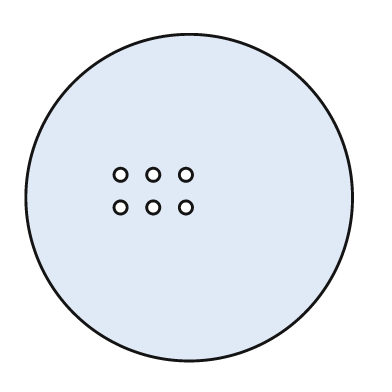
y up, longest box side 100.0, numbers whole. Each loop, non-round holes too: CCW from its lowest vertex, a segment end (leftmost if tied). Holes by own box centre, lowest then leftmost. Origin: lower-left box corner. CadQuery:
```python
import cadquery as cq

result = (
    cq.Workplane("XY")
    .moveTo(50.0, 50.0)
    .circle(50.0)
    .moveTo(29.0, 47.0)
    .circle(2.0)
    .moveTo(39.0, 47.0)
    .circle(2.0)
    .moveTo(49.0, 47.0)
    .circle(2.0)
    .moveTo(29.0, 57.0)
    .circle(2.0)
    .moveTo(39.0, 57.0)
    .circle(2.0)
    .moveTo(49.0, 57.0)
    .circle(2.0)
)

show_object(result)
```